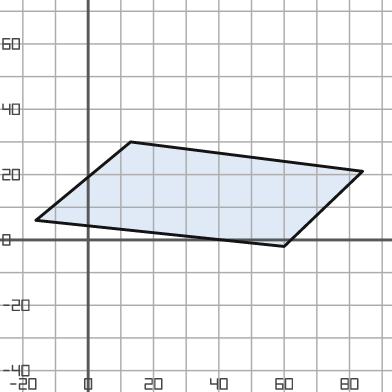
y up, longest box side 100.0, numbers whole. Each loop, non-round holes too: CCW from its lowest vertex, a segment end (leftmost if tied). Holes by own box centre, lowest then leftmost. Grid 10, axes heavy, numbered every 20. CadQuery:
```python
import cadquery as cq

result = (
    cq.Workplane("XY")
    .moveTo(60.0, -2.0)
    .lineTo(84.0, 21.0)
    .lineTo(13.0, 30.0)
    .lineTo(-16.0, 6.0)
    .close()
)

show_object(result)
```